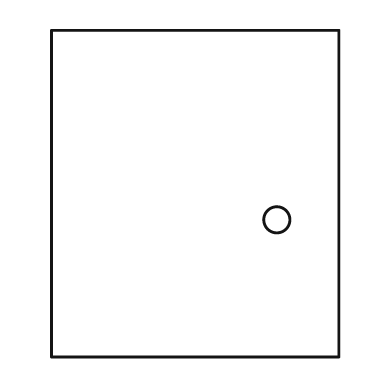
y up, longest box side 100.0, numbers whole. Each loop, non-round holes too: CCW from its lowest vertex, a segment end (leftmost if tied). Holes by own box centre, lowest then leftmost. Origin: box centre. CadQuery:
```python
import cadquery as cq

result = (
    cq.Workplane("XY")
    .moveTo(-44.0, -50.0)
    .lineTo(44.0, -50.0)
    .lineTo(44.0, 50.0)
    .lineTo(-44.0, 50.0)
    .close()
    .moveTo(25.0, -8.0)
    .circle(4.0)
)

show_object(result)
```